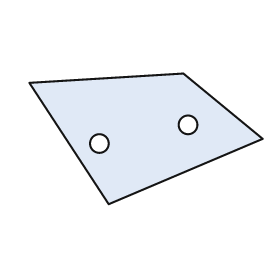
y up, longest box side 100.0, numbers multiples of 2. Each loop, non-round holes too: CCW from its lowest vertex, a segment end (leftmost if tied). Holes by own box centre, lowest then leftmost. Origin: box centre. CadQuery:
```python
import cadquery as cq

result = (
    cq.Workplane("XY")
    .moveTo(-16.0, -28.0)
    .lineTo(50.0, 0.0)
    .lineTo(16.0, 28.0)
    .lineTo(-50.0, 24.0)
    .close()
    .moveTo(-20.0, -2.0)
    .circle(4.0)
    .moveTo(18.0, 6.0)
    .circle(4.0)
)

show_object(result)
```